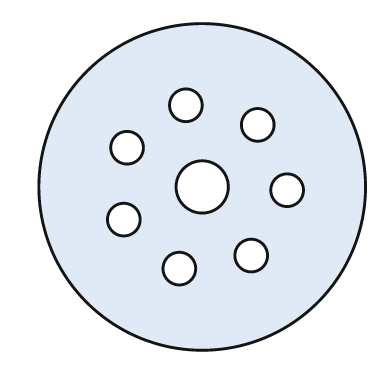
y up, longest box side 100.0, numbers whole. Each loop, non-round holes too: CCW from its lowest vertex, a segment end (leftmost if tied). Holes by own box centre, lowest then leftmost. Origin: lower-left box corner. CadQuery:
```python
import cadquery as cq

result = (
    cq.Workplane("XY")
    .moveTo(50.0, 50.0)
    .circle(50.0)
    .moveTo(43.0, 25.0)
    .circle(5.0)
    .moveTo(65.0, 29.0)
    .circle(5.0)
    .moveTo(26.0, 40.0)
    .circle(5.0)
    .moveTo(76.0, 49.0)
    .circle(5.0)
    .moveTo(50.0, 50.0)
    .circle(8.0)
    .moveTo(27.0, 62.0)
    .circle(5.0)
    .moveTo(67.0, 69.0)
    .circle(5.0)
    .moveTo(45.0, 75.0)
    .circle(5.0)
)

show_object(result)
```